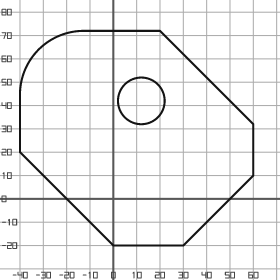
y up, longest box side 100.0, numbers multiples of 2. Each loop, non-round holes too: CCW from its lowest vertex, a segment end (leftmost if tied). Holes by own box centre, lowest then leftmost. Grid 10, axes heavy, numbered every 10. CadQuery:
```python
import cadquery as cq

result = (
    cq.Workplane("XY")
    .moveTo(0.0, -20.0)
    .lineTo(30.0, -20.0)
    .lineTo(60.0, 10.0)
    .lineTo(60.0, 32.0)
    .lineTo(20.0, 72.0)
    .lineTo(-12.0, 72.0)
    .threePointArc((-32.0, 64.0), (-40.0, 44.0))
    .lineTo(-40.0, 20.0)
    .close()
    .moveTo(12.0, 42.0)
    .circle(10.0)
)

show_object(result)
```